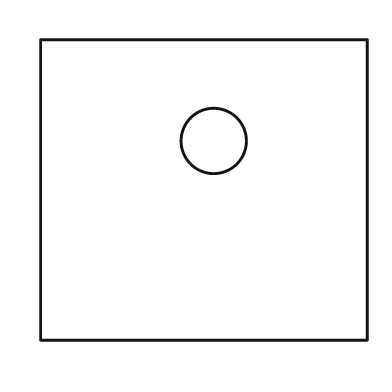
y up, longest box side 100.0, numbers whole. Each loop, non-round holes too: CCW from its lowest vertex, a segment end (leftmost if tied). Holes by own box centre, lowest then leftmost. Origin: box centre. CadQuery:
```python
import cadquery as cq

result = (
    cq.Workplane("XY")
    .moveTo(-50.0, -46.0)
    .lineTo(50.0, -46.0)
    .lineTo(50.0, 46.0)
    .lineTo(-50.0, 46.0)
    .close()
    .moveTo(3.0, 15.0)
    .circle(10.0)
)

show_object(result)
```